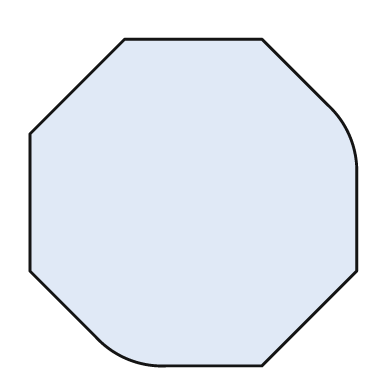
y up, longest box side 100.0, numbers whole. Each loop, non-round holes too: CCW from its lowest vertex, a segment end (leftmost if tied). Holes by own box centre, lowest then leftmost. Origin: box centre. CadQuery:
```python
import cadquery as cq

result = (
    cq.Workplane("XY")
    .moveTo(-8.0, -50.0)
    .lineTo(21.0, -50.0)
    .lineTo(50.0, -21.0)
    .lineTo(50.0, 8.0)
    .threePointArc((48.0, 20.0), (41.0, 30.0))
    .lineTo(21.0, 50.0)
    .lineTo(-21.0, 50.0)
    .lineTo(-50.0, 21.0)
    .lineTo(-50.0, -21.0)
    .lineTo(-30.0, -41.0)
    .threePointArc((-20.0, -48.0), (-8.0, -50.0))
    .close()
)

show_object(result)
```